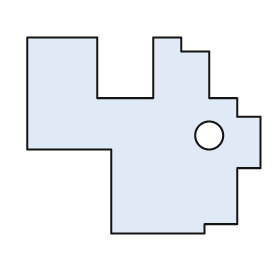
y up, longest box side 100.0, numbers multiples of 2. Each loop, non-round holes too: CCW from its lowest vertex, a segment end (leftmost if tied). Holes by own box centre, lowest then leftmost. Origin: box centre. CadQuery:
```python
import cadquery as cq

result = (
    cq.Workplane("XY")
    .moveTo(-14.0, -42.0)
    .lineTo(26.0, -42.0)
    .lineTo(26.0, -38.0)
    .lineTo(40.0, -38.0)
    .lineTo(40.0, -14.0)
    .lineTo(50.0, -14.0)
    .lineTo(50.0, 8.0)
    .lineTo(40.0, 8.0)
    .lineTo(40.0, 16.0)
    .lineTo(28.0, 16.0)
    .lineTo(28.0, 36.0)
    .lineTo(16.0, 36.0)
    .lineTo(16.0, 42.0)
    .lineTo(4.0, 42.0)
    .lineTo(4.0, 16.0)
    .lineTo(-20.0, 16.0)
    .lineTo(-20.0, 42.0)
    .lineTo(-50.0, 42.0)
    .lineTo(-50.0, -6.0)
    .lineTo(-14.0, -6.0)
    .close()
    .moveTo(28.0, 0.0)
    .circle(6.0)
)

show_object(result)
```